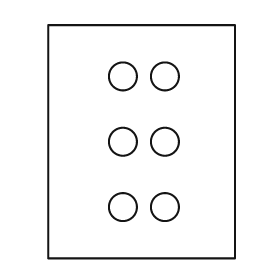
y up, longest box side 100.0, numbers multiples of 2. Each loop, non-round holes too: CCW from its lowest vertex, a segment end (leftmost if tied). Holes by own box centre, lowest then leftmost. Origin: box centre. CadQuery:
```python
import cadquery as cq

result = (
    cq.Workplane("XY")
    .moveTo(-40.0, -50.0)
    .lineTo(40.0, -50.0)
    .lineTo(40.0, 50.0)
    .lineTo(-40.0, 50.0)
    .close()
    .moveTo(-8.0, -28.0)
    .circle(6.0)
    .moveTo(10.0, -28.0)
    .circle(6.0)
    .moveTo(-8.0, 0.0)
    .circle(6.0)
    .moveTo(10.0, 0.0)
    .circle(6.0)
    .moveTo(-8.0, 28.0)
    .circle(6.0)
    .moveTo(10.0, 28.0)
    .circle(6.0)
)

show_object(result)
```